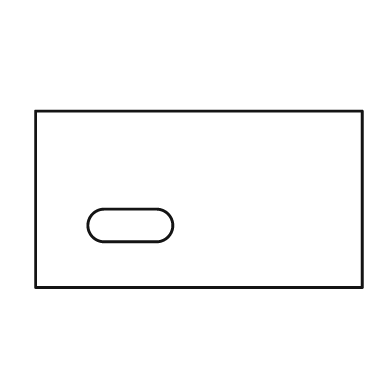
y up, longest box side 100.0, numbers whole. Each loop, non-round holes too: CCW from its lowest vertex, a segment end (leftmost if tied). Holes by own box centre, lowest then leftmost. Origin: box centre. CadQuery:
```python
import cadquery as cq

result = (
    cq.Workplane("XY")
    .moveTo(-50.0, -27.0)
    .lineTo(50.0, -27.0)
    .lineTo(50.0, 27.0)
    .lineTo(-50.0, 27.0)
    .close()
    .moveTo(-29.0, -13.0)
    .lineTo(-13.0, -13.0)
    .threePointArc((-8.0, -8.0), (-13.0, -3.0))
    .lineTo(-29.0, -3.0)
    .threePointArc((-34.0, -8.0), (-29.0, -13.0))
    .close()
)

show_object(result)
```